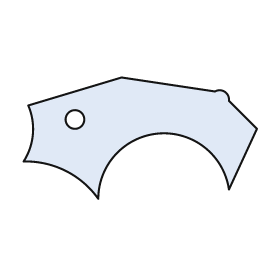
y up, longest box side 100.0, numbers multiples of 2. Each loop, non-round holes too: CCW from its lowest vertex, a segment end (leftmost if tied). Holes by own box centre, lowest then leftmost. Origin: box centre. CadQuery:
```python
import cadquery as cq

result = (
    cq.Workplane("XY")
    .moveTo(-18.0, -26.0)
    .threePointArc((8.0, 2.0), (38.0, -22.0))
    .lineTo(50.0, 4.0)
    .lineTo(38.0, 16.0)
    .threePointArc((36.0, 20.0), (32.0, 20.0))
    .lineTo(-8.0, 26.0)
    .lineTo(-48.0, 14.0)
    .threePointArc((-46.0, 2.0), (-50.0, -10.0))
    .threePointArc((-32.0, -14.0), (-18.0, -26.0))
    .close()
    .moveTo(-28.0, 8.0)
    .circle(4.0)
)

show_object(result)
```